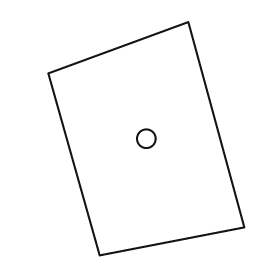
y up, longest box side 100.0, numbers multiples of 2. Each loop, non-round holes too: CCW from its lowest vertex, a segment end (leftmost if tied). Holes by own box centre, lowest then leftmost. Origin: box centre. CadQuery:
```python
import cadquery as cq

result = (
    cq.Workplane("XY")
    .moveTo(-20.0, -50.0)
    .lineTo(42.0, -38.0)
    .lineTo(18.0, 50.0)
    .lineTo(-42.0, 28.0)
    .close()
    .moveTo(0.0, 0.0)
    .circle(4.0)
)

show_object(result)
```